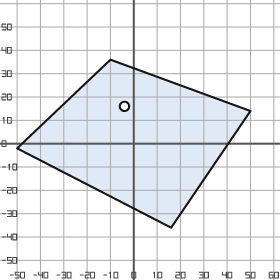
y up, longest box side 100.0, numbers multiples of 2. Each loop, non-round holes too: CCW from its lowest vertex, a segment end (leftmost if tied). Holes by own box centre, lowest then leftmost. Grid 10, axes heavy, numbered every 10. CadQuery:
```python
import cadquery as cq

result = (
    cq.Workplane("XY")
    .moveTo(16.0, -36.0)
    .lineTo(50.0, 14.0)
    .lineTo(-10.0, 36.0)
    .lineTo(-50.0, -2.0)
    .close()
    .moveTo(-4.0, 16.0)
    .circle(2.0)
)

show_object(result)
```